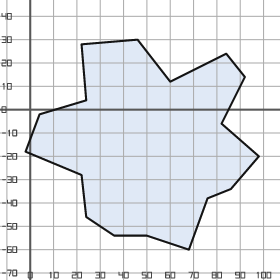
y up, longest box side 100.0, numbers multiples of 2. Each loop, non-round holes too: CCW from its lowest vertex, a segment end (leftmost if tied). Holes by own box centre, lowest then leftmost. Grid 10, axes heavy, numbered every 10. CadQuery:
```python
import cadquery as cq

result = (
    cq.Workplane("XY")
    .moveTo(68.0, -60.0)
    .lineTo(76.0, -38.0)
    .lineTo(86.0, -34.0)
    .lineTo(98.0, -20.0)
    .lineTo(82.0, -6.0)
    .lineTo(92.0, 14.0)
    .lineTo(84.0, 24.0)
    .lineTo(60.0, 12.0)
    .lineTo(46.0, 30.0)
    .lineTo(22.0, 28.0)
    .lineTo(24.0, 4.0)
    .lineTo(4.0, -2.0)
    .lineTo(-2.0, -18.0)
    .lineTo(22.0, -28.0)
    .lineTo(24.0, -46.0)
    .lineTo(36.0, -54.0)
    .lineTo(50.0, -54.0)
    .close()
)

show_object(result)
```